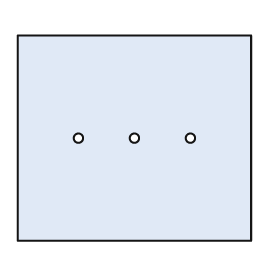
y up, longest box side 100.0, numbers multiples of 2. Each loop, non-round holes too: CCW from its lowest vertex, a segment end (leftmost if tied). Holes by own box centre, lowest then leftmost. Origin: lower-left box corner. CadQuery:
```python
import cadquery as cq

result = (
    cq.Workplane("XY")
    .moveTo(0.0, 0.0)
    .lineTo(100.0, 0.0)
    .lineTo(100.0, 88.0)
    .lineTo(0.0, 88.0)
    .close()
    .moveTo(26.0, 44.0)
    .circle(2.0)
    .moveTo(50.0, 44.0)
    .circle(2.0)
    .moveTo(74.0, 44.0)
    .circle(2.0)
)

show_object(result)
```